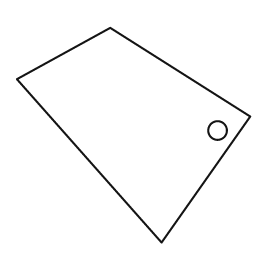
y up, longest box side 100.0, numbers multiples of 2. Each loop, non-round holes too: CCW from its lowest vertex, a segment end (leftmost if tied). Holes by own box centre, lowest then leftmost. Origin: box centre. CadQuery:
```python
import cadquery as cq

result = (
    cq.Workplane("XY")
    .moveTo(12.0, -46.0)
    .lineTo(50.0, 8.0)
    .lineTo(-10.0, 46.0)
    .lineTo(-50.0, 24.0)
    .close()
    .moveTo(36.0, 2.0)
    .circle(4.0)
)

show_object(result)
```